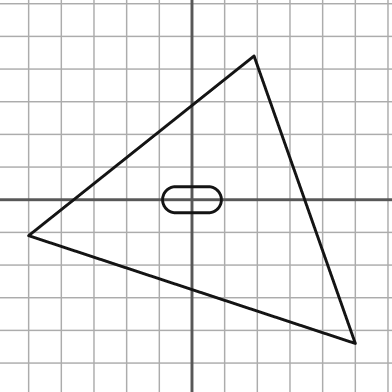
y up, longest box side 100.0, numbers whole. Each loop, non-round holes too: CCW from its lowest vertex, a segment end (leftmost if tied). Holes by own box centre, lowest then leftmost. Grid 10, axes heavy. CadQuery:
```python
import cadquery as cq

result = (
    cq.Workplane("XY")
    .moveTo(50.0, -44.0)
    .lineTo(19.0, 44.0)
    .lineTo(-50.0, -11.0)
    .close()
    .moveTo(-5.0, -4.0)
    .lineTo(5.0, -4.0)
    .threePointArc((9.0, 0.0), (5.0, 4.0))
    .lineTo(-5.0, 4.0)
    .threePointArc((-9.0, 0.0), (-5.0, -4.0))
    .close()
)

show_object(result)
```